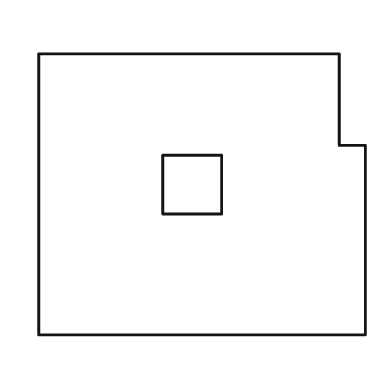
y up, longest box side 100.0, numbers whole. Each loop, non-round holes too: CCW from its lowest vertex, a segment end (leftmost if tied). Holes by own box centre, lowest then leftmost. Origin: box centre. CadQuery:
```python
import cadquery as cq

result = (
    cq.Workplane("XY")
    .moveTo(-50.0, -43.0)
    .lineTo(50.0, -43.0)
    .lineTo(50.0, 15.0)
    .lineTo(42.0, 15.0)
    .lineTo(42.0, 43.0)
    .lineTo(-50.0, 43.0)
    .close()
    .moveTo(-12.0, -6.0)
    .lineTo(6.0, -6.0)
    .lineTo(6.0, 12.0)
    .lineTo(-12.0, 12.0)
    .close()
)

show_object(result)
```